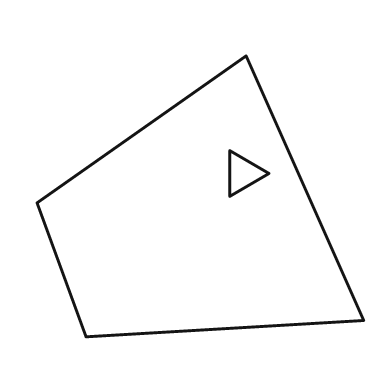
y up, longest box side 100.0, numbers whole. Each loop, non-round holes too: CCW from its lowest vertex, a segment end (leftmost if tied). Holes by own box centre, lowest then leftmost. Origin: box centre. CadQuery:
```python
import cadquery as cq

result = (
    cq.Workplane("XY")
    .moveTo(-35.0, -43.0)
    .lineTo(50.0, -38.0)
    .lineTo(14.0, 43.0)
    .lineTo(-50.0, -2.0)
    .close()
    .moveTo(9.0, 0.0)
    .lineTo(21.0, 7.0)
    .lineTo(9.0, 14.0)
    .close()
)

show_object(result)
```